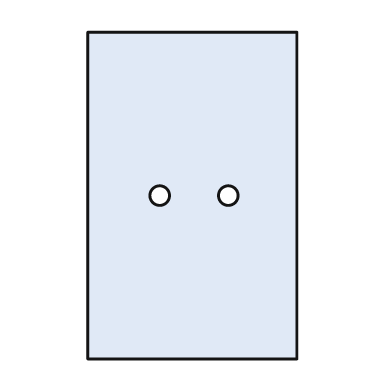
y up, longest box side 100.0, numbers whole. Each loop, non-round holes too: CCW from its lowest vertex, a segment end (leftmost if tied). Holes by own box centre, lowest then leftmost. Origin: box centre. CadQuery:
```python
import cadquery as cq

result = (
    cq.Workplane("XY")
    .moveTo(-32.0, -50.0)
    .lineTo(32.0, -50.0)
    .lineTo(32.0, 50.0)
    .lineTo(-32.0, 50.0)
    .close()
    .moveTo(-10.0, 0.0)
    .circle(3.0)
    .moveTo(11.0, 0.0)
    .circle(3.0)
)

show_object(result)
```